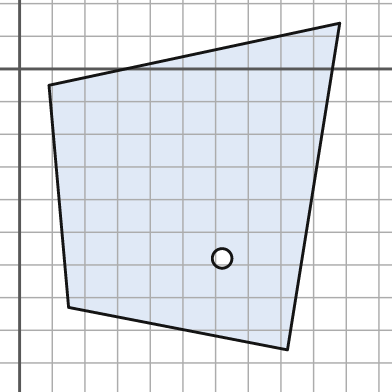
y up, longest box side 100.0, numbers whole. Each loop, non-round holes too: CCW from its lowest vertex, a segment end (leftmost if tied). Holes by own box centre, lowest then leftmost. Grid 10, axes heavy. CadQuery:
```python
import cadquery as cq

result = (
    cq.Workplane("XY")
    .moveTo(82.0, -86.0)
    .lineTo(98.0, 14.0)
    .lineTo(9.0, -5.0)
    .lineTo(15.0, -73.0)
    .close()
    .moveTo(62.0, -58.0)
    .circle(3.0)
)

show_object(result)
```